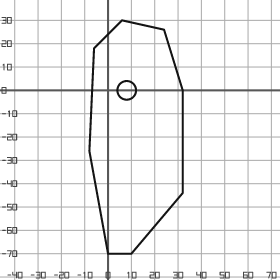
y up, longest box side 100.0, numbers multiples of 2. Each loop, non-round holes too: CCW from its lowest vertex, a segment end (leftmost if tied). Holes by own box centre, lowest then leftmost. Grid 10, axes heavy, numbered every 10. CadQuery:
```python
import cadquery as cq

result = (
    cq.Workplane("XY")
    .moveTo(0.0, -70.0)
    .lineTo(10.0, -70.0)
    .lineTo(32.0, -44.0)
    .lineTo(32.0, 0.0)
    .lineTo(24.0, 26.0)
    .lineTo(6.0, 30.0)
    .lineTo(-6.0, 18.0)
    .lineTo(-8.0, -26.0)
    .close()
    .moveTo(8.0, 0.0)
    .circle(4.0)
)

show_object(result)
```